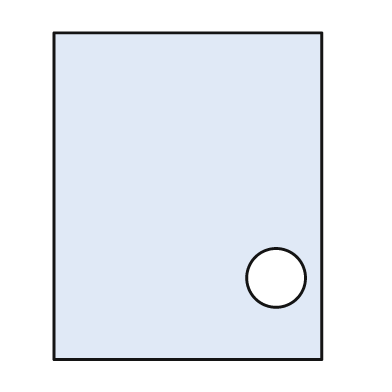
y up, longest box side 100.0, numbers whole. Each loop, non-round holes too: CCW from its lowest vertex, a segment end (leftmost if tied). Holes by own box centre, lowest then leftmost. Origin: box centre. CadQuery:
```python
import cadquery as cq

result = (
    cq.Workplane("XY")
    .moveTo(-41.0, -50.0)
    .lineTo(41.0, -50.0)
    .lineTo(41.0, 50.0)
    .lineTo(-41.0, 50.0)
    .close()
    .moveTo(27.0, -25.0)
    .circle(9.0)
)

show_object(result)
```